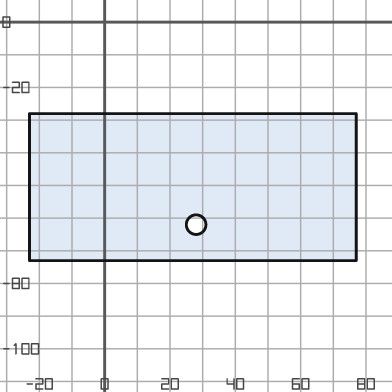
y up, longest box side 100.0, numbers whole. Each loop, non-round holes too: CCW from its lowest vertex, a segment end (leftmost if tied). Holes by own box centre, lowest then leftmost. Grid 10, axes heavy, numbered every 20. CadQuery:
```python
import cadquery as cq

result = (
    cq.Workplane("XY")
    .moveTo(-23.0, -73.0)
    .lineTo(77.0, -73.0)
    .lineTo(77.0, -28.0)
    .lineTo(-23.0, -28.0)
    .close()
    .moveTo(28.0, -62.0)
    .circle(3.0)
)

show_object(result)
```